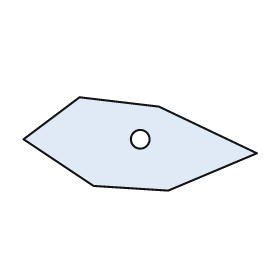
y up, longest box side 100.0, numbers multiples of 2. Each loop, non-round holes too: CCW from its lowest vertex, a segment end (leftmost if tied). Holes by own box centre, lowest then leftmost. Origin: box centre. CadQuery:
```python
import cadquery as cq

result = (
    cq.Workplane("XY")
    .moveTo(12.0, -20.0)
    .lineTo(50.0, -4.0)
    .lineTo(8.0, 16.0)
    .lineTo(-26.0, 20.0)
    .lineTo(-50.0, 2.0)
    .lineTo(-20.0, -18.0)
    .close()
    .moveTo(0.0, 2.0)
    .circle(4.0)
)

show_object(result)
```